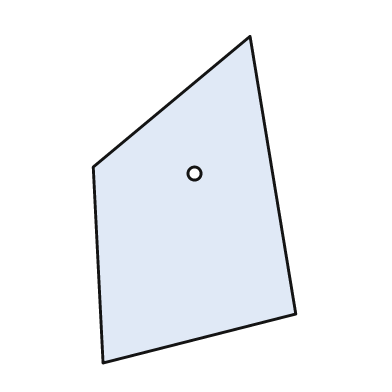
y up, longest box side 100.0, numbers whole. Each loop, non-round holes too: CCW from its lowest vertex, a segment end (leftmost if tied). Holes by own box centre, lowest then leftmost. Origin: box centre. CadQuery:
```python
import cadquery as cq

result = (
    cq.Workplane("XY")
    .moveTo(-28.0, -50.0)
    .lineTo(31.0, -35.0)
    .lineTo(17.0, 50.0)
    .lineTo(-31.0, 10.0)
    .close()
    .moveTo(0.0, 8.0)
    .circle(2.0)
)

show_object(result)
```